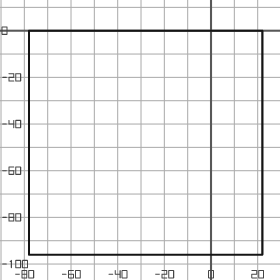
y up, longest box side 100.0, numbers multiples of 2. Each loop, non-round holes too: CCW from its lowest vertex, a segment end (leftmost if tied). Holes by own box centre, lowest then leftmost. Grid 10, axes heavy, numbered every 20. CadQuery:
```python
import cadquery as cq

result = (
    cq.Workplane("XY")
    .moveTo(-78.0, -96.0)
    .lineTo(22.0, -96.0)
    .lineTo(22.0, 0.0)
    .lineTo(-78.0, 0.0)
    .close()
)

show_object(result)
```